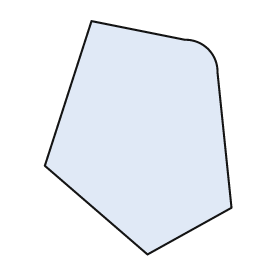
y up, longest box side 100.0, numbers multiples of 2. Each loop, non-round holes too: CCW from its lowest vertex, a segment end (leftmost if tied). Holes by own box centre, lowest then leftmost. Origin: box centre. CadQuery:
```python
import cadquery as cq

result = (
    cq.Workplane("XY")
    .moveTo(4.0, -50.0)
    .lineTo(40.0, -30.0)
    .lineTo(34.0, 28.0)
    .threePointArc((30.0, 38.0), (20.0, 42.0))
    .lineTo(-20.0, 50.0)
    .lineTo(-40.0, -12.0)
    .close()
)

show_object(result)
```